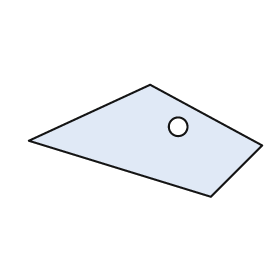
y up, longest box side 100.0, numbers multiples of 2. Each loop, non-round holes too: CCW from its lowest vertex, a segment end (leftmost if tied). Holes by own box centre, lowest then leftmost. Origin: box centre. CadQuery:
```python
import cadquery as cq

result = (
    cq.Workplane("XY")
    .moveTo(28.0, -24.0)
    .lineTo(50.0, -2.0)
    .lineTo(2.0, 24.0)
    .lineTo(-50.0, 0.0)
    .close()
    .moveTo(14.0, 6.0)
    .circle(4.0)
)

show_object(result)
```